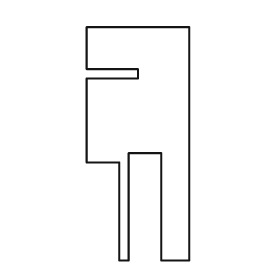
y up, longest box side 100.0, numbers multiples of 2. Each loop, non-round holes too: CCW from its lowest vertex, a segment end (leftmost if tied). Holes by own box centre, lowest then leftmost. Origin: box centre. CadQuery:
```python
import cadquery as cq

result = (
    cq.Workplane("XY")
    .moveTo(-8.0, -50.0)
    .lineTo(-4.0, -50.0)
    .lineTo(-4.0, -4.0)
    .lineTo(10.0, -4.0)
    .lineTo(10.0, -50.0)
    .lineTo(22.0, -50.0)
    .lineTo(22.0, 50.0)
    .lineTo(-22.0, 50.0)
    .lineTo(-22.0, 32.0)
    .lineTo(0.0, 32.0)
    .lineTo(0.0, 28.0)
    .lineTo(-22.0, 28.0)
    .lineTo(-22.0, -8.0)
    .lineTo(-8.0, -8.0)
    .close()
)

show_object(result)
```